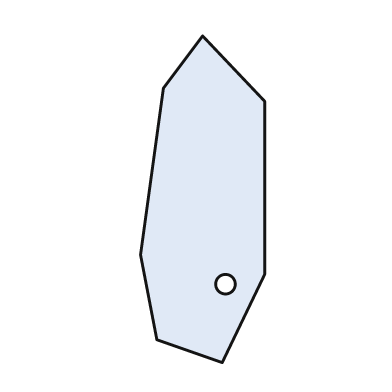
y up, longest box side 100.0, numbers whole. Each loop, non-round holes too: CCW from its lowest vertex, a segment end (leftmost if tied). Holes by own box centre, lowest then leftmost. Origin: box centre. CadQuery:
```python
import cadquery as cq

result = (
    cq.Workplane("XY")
    .moveTo(6.0, -50.0)
    .lineTo(19.0, -23.0)
    .lineTo(19.0, 30.0)
    .lineTo(0.0, 50.0)
    .lineTo(-12.0, 34.0)
    .lineTo(-19.0, -17.0)
    .lineTo(-14.0, -43.0)
    .close()
    .moveTo(7.0, -26.0)
    .circle(3.0)
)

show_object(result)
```